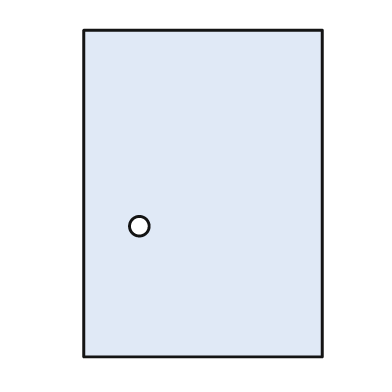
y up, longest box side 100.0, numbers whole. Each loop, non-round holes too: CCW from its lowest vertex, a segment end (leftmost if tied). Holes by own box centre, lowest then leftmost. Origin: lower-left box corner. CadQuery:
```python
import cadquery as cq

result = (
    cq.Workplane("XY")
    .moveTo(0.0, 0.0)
    .lineTo(73.0, 0.0)
    .lineTo(73.0, 100.0)
    .lineTo(0.0, 100.0)
    .close()
    .moveTo(17.0, 40.0)
    .circle(3.0)
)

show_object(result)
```